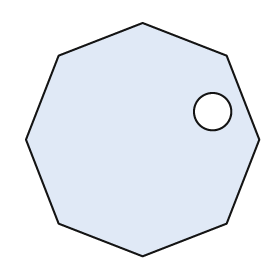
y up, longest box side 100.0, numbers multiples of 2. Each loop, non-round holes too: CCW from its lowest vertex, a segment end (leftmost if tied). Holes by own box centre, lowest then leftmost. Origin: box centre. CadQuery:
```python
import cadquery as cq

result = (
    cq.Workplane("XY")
    .moveTo(0.0, -50.0)
    .lineTo(36.0, -36.0)
    .lineTo(50.0, 0.0)
    .lineTo(36.0, 36.0)
    .lineTo(0.0, 50.0)
    .lineTo(-36.0, 36.0)
    .lineTo(-50.0, 0.0)
    .lineTo(-36.0, -36.0)
    .close()
    .moveTo(30.0, 12.0)
    .circle(8.0)
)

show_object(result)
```